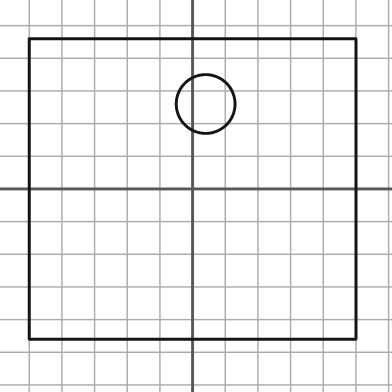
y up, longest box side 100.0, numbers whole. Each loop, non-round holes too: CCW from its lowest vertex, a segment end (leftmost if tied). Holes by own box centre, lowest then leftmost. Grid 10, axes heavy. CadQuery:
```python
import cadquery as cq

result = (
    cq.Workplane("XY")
    .moveTo(-50.0, -46.0)
    .lineTo(50.0, -46.0)
    .lineTo(50.0, 46.0)
    .lineTo(-50.0, 46.0)
    .close()
    .moveTo(4.0, 26.0)
    .circle(9.0)
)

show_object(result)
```